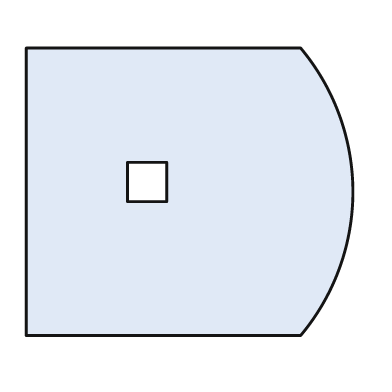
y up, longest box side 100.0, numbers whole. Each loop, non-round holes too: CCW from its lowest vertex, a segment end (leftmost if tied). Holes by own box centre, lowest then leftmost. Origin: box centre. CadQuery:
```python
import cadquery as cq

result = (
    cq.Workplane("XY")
    .moveTo(-50.0, -44.0)
    .lineTo(34.0, -44.0)
    .threePointArc((50.0, 0.0), (34.0, 44.0))
    .lineTo(-50.0, 44.0)
    .close()
    .moveTo(-19.0, -3.0)
    .lineTo(-7.0, -3.0)
    .lineTo(-7.0, 9.0)
    .lineTo(-19.0, 9.0)
    .close()
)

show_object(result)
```